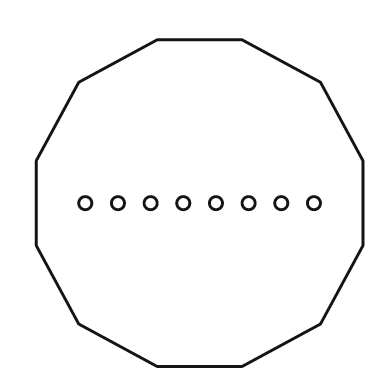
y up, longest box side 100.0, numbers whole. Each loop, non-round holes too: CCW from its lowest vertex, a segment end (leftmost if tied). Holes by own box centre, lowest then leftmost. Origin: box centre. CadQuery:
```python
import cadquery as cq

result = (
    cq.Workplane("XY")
    .moveTo(-13.0, -50.0)
    .lineTo(13.0, -50.0)
    .lineTo(37.0, -37.0)
    .lineTo(50.0, -13.0)
    .lineTo(50.0, 13.0)
    .lineTo(37.0, 37.0)
    .lineTo(13.0, 50.0)
    .lineTo(-13.0, 50.0)
    .lineTo(-37.0, 37.0)
    .lineTo(-50.0, 13.0)
    .lineTo(-50.0, -13.0)
    .lineTo(-37.0, -37.0)
    .close()
    .moveTo(-35.0, 0.0)
    .circle(2.0)
    .moveTo(-25.0, 0.0)
    .circle(2.0)
    .moveTo(-15.0, 0.0)
    .circle(2.0)
    .moveTo(-5.0, 0.0)
    .circle(2.0)
    .moveTo(5.0, 0.0)
    .circle(2.0)
    .moveTo(15.0, 0.0)
    .circle(2.0)
    .moveTo(25.0, 0.0)
    .circle(2.0)
    .moveTo(35.0, 0.0)
    .circle(2.0)
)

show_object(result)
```